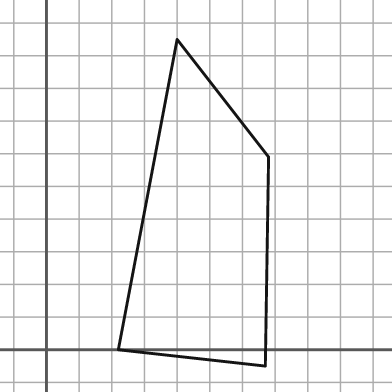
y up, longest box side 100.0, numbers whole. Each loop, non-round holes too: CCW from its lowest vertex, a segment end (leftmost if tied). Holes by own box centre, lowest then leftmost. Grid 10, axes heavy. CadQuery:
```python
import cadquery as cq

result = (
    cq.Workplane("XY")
    .moveTo(67.0, -5.0)
    .lineTo(68.0, 59.0)
    .lineTo(40.0, 95.0)
    .lineTo(22.0, 0.0)
    .close()
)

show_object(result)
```